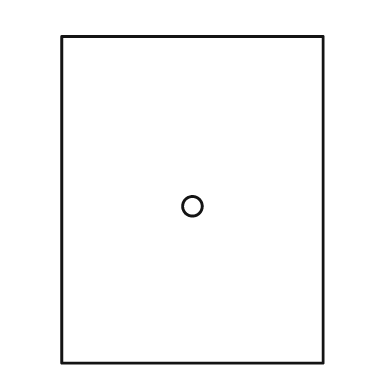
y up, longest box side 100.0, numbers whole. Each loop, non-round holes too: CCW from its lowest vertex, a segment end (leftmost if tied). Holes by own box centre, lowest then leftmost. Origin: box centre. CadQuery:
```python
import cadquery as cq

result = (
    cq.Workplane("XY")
    .moveTo(-40.0, -50.0)
    .lineTo(40.0, -50.0)
    .lineTo(40.0, 50.0)
    .lineTo(-40.0, 50.0)
    .close()
    .moveTo(0.0, -2.0)
    .circle(3.0)
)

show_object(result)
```